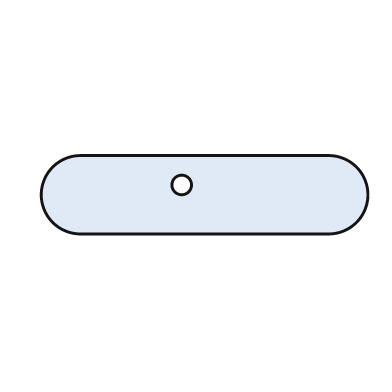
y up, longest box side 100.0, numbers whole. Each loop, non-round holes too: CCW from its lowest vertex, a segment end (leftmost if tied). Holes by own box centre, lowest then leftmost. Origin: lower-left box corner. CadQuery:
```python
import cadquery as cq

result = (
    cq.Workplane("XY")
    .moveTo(12.0, 0.0)
    .lineTo(88.0, 0.0)
    .threePointArc((100.0, 12.0), (88.0, 24.0))
    .lineTo(12.0, 24.0)
    .threePointArc((0.0, 12.0), (12.0, 0.0))
    .close()
    .moveTo(43.0, 15.0)
    .circle(3.0)
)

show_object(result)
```